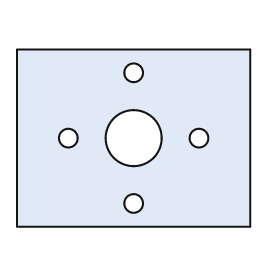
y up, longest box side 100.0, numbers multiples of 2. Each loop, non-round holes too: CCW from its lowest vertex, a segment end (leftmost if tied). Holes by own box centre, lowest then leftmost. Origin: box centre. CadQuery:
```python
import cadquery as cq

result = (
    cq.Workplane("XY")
    .moveTo(-50.0, -38.0)
    .lineTo(50.0, -38.0)
    .lineTo(50.0, 38.0)
    .lineTo(-50.0, 38.0)
    .close()
    .moveTo(0.0, -28.0)
    .circle(4.0)
    .moveTo(-28.0, 0.0)
    .circle(4.0)
    .moveTo(0.0, 0.0)
    .circle(12.0)
    .moveTo(28.0, 0.0)
    .circle(4.0)
    .moveTo(0.0, 28.0)
    .circle(4.0)
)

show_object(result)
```